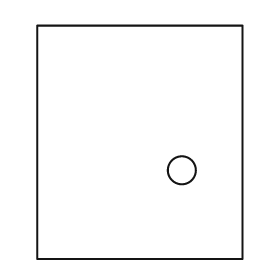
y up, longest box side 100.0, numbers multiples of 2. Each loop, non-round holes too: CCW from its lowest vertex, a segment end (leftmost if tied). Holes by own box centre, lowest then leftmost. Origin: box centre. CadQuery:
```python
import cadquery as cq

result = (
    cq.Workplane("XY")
    .moveTo(-44.0, -50.0)
    .lineTo(44.0, -50.0)
    .lineTo(44.0, 50.0)
    .lineTo(-44.0, 50.0)
    .close()
    .moveTo(18.0, -12.0)
    .circle(6.0)
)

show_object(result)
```